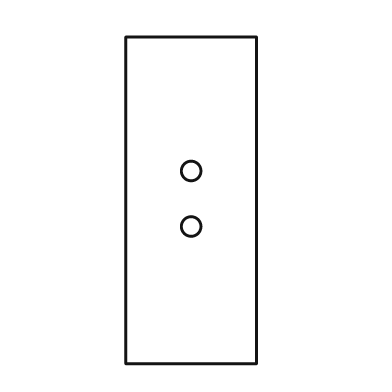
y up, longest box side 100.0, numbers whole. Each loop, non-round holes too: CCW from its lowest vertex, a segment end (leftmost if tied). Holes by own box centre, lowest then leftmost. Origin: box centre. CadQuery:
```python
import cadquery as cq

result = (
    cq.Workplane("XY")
    .moveTo(-20.0, -50.0)
    .lineTo(20.0, -50.0)
    .lineTo(20.0, 50.0)
    .lineTo(-20.0, 50.0)
    .close()
    .moveTo(0.0, -8.0)
    .circle(3.0)
    .moveTo(0.0, 9.0)
    .circle(3.0)
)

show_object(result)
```